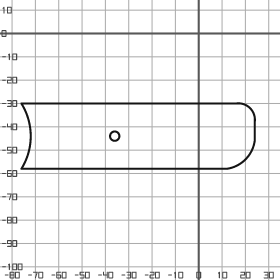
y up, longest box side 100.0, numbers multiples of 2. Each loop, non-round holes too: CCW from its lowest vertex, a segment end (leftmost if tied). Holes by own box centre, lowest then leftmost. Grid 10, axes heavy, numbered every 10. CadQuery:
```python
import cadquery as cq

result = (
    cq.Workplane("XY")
    .moveTo(-76.0, -58.0)
    .lineTo(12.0, -58.0)
    .threePointArc((20.0, -54.0), (24.0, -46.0))
    .lineTo(24.0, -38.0)
    .threePointArc((22.0, -32.0), (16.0, -30.0))
    .lineTo(-76.0, -30.0)
    .threePointArc((-72.0, -44.0), (-76.0, -58.0))
    .close()
    .moveTo(-36.0, -44.0)
    .circle(2.0)
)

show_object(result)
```